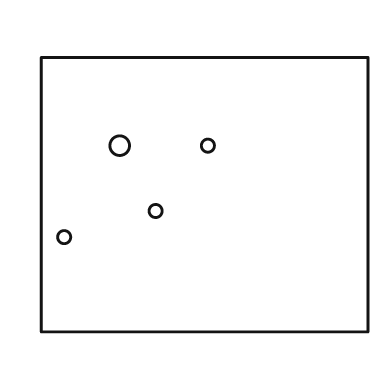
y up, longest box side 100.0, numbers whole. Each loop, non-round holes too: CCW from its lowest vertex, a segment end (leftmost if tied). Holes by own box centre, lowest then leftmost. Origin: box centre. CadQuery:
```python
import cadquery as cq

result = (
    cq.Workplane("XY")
    .moveTo(-50.0, -42.0)
    .lineTo(50.0, -42.0)
    .lineTo(50.0, 42.0)
    .lineTo(-50.0, 42.0)
    .close()
    .moveTo(-43.0, -13.0)
    .circle(2.0)
    .moveTo(-15.0, -5.0)
    .circle(2.0)
    .moveTo(-26.0, 15.0)
    .circle(3.0)
    .moveTo(1.0, 15.0)
    .circle(2.0)
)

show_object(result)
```